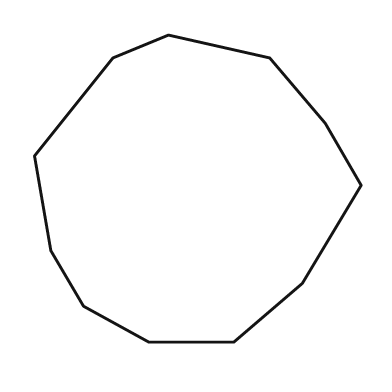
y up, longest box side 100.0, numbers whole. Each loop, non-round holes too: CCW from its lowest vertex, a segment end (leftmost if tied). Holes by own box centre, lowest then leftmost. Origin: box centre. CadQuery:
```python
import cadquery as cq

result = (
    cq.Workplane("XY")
    .moveTo(-15.0, -47.0)
    .lineTo(11.0, -47.0)
    .lineTo(32.0, -29.0)
    .lineTo(50.0, 1.0)
    .lineTo(39.0, 20.0)
    .lineTo(22.0, 40.0)
    .lineTo(-9.0, 47.0)
    .lineTo(-26.0, 40.0)
    .lineTo(-50.0, 10.0)
    .lineTo(-45.0, -19.0)
    .lineTo(-35.0, -36.0)
    .close()
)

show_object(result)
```